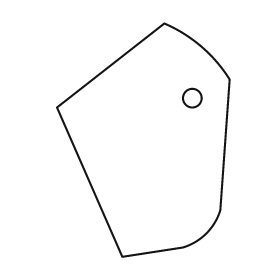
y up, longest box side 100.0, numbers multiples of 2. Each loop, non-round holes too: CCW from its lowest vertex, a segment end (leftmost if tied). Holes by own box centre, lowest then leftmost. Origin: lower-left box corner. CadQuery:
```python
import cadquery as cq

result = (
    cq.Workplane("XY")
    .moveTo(28.0, 0.0)
    .lineTo(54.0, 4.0)
    .threePointArc((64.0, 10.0), (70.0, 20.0))
    .lineTo(74.0, 76.0)
    .threePointArc((62.0, 90.0), (46.0, 100.0))
    .lineTo(0.0, 64.0)
    .close()
    .moveTo(58.0, 68.0)
    .circle(4.0)
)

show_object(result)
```